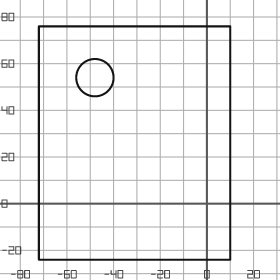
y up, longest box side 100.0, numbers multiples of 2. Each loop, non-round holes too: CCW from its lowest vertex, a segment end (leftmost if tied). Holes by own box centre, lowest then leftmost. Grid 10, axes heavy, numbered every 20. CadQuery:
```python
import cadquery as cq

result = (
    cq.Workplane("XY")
    .moveTo(-72.0, -24.0)
    .lineTo(10.0, -24.0)
    .lineTo(10.0, 76.0)
    .lineTo(-72.0, 76.0)
    .close()
    .moveTo(-48.0, 54.0)
    .circle(8.0)
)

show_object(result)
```